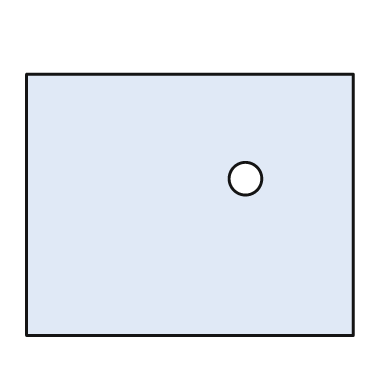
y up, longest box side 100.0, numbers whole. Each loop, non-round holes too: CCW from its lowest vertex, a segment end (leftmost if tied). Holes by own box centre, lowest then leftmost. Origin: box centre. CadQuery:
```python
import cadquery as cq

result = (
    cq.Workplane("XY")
    .moveTo(-50.0, -40.0)
    .lineTo(50.0, -40.0)
    .lineTo(50.0, 40.0)
    .lineTo(-50.0, 40.0)
    .close()
    .moveTo(17.0, 8.0)
    .circle(5.0)
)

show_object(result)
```